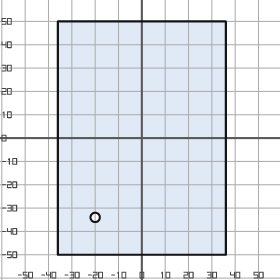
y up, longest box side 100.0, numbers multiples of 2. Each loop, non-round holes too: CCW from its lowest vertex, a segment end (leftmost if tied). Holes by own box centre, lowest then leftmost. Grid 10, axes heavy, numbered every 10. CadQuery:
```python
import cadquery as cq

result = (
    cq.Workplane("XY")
    .moveTo(-36.0, -50.0)
    .lineTo(36.0, -50.0)
    .lineTo(36.0, 50.0)
    .lineTo(-36.0, 50.0)
    .close()
    .moveTo(-20.0, -34.0)
    .circle(2.0)
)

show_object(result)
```